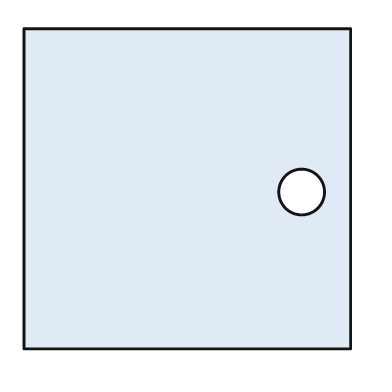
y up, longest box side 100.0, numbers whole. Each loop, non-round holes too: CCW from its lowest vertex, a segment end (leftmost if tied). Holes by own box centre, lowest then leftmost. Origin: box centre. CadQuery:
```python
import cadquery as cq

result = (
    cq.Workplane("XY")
    .moveTo(-50.0, -49.0)
    .lineTo(50.0, -49.0)
    .lineTo(50.0, 49.0)
    .lineTo(-50.0, 49.0)
    .close()
    .moveTo(35.0, -1.0)
    .circle(7.0)
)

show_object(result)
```